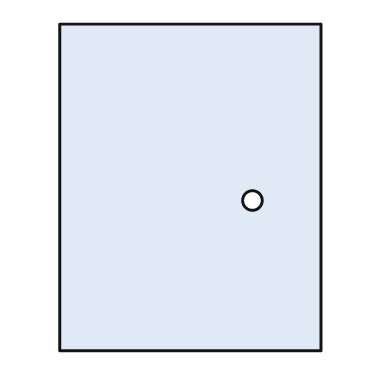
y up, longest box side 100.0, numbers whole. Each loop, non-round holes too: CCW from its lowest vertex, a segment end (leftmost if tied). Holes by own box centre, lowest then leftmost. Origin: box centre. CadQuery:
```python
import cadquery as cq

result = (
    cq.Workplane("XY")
    .moveTo(-40.0, -50.0)
    .lineTo(40.0, -50.0)
    .lineTo(40.0, 50.0)
    .lineTo(-40.0, 50.0)
    .close()
    .moveTo(19.0, -4.0)
    .circle(3.0)
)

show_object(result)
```